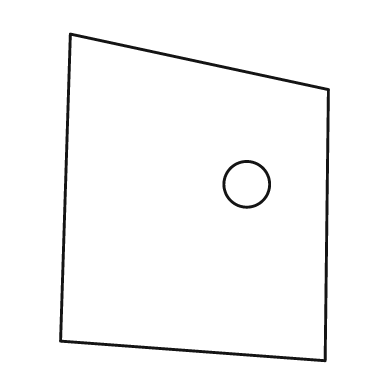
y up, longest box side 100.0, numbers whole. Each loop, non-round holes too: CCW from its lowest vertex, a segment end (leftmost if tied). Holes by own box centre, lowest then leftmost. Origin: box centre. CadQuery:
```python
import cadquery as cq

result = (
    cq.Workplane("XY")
    .moveTo(40.0, -50.0)
    .lineTo(41.0, 33.0)
    .lineTo(-38.0, 50.0)
    .lineTo(-41.0, -44.0)
    .close()
    .moveTo(16.0, 4.0)
    .circle(7.0)
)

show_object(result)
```